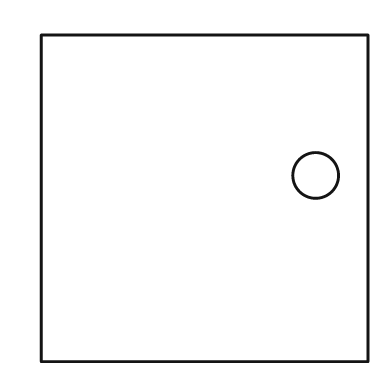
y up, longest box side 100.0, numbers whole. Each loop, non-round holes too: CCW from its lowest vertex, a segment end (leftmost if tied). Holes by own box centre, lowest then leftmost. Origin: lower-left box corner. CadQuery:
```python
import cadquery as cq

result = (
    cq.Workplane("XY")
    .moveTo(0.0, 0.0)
    .lineTo(100.0, 0.0)
    .lineTo(100.0, 100.0)
    .lineTo(0.0, 100.0)
    .close()
    .moveTo(84.0, 57.0)
    .circle(7.0)
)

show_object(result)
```